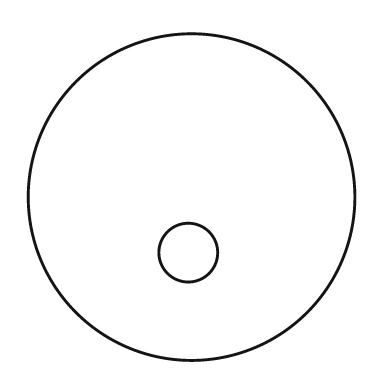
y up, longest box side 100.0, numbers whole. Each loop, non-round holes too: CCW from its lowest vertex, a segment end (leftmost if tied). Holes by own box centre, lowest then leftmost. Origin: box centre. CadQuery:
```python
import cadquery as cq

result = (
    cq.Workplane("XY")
    .moveTo(0.0, 0.0)
    .circle(50.0)
    .moveTo(-1.0, -17.0)
    .circle(9.0)
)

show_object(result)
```